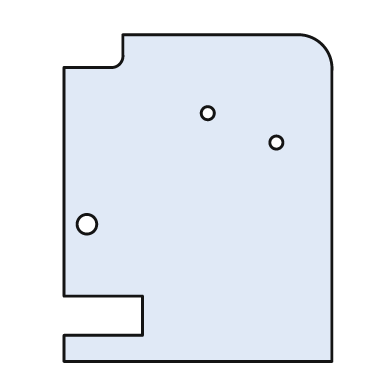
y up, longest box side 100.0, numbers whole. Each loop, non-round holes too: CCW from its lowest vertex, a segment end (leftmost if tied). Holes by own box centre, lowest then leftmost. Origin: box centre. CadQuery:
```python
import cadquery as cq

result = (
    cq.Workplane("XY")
    .moveTo(-41.0, -50.0)
    .lineTo(41.0, -50.0)
    .lineTo(41.0, 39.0)
    .threePointArc((38.0, 47.0), (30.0, 50.0))
    .lineTo(-23.0, 50.0)
    .lineTo(-23.0, 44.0)
    .threePointArc((-24.0, 41.0), (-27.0, 40.0))
    .lineTo(-41.0, 40.0)
    .lineTo(-41.0, -30.0)
    .lineTo(-17.0, -30.0)
    .lineTo(-17.0, -42.0)
    .lineTo(-41.0, -42.0)
    .close()
    .moveTo(-34.0, -8.0)
    .circle(3.0)
    .moveTo(24.0, 17.0)
    .circle(2.0)
    .moveTo(3.0, 26.0)
    .circle(2.0)
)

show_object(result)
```